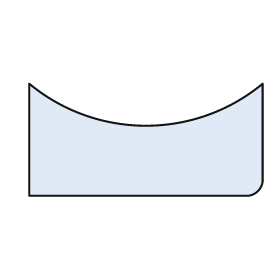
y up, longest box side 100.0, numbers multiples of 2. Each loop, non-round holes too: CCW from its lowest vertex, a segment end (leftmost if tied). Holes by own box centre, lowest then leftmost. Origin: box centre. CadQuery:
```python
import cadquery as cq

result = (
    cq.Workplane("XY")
    .moveTo(-50.0, -24.0)
    .lineTo(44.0, -24.0)
    .threePointArc((48.0, -22.0), (50.0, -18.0))
    .lineTo(50.0, 24.0)
    .threePointArc((0.0, 6.0), (-50.0, 24.0))
    .close()
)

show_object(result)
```